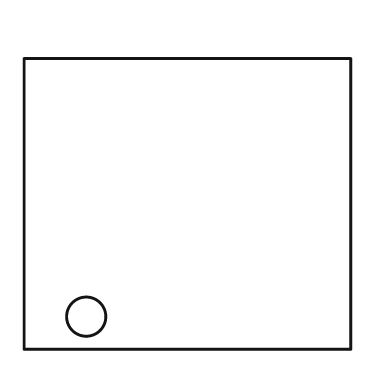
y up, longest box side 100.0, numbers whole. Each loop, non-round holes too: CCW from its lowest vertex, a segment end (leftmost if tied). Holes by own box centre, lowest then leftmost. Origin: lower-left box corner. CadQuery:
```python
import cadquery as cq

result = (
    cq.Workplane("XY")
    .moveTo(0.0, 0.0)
    .lineTo(100.0, 0.0)
    .lineTo(100.0, 89.0)
    .lineTo(0.0, 89.0)
    .close()
    .moveTo(19.0, 10.0)
    .circle(6.0)
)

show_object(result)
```